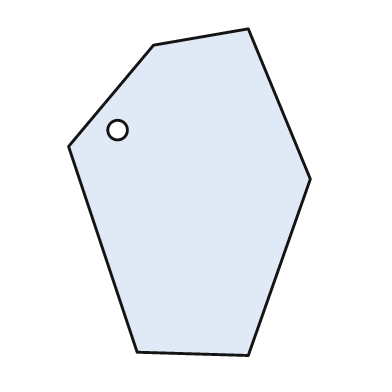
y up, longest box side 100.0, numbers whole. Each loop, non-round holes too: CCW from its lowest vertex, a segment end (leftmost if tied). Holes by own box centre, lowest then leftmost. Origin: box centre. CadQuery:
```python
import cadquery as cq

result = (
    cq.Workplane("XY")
    .moveTo(18.0, -50.0)
    .lineTo(37.0, 4.0)
    .lineTo(18.0, 50.0)
    .lineTo(-11.0, 45.0)
    .lineTo(-37.0, 14.0)
    .lineTo(-16.0, -49.0)
    .close()
    .moveTo(-22.0, 19.0)
    .circle(3.0)
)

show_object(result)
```